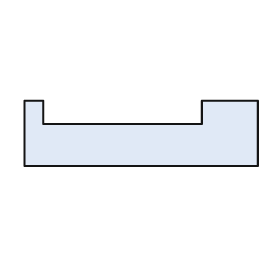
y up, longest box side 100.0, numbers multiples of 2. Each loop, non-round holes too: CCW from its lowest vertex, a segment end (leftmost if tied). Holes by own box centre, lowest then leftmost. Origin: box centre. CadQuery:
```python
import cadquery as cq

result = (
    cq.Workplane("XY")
    .moveTo(-50.0, -14.0)
    .lineTo(50.0, -14.0)
    .lineTo(50.0, 14.0)
    .lineTo(26.0, 14.0)
    .lineTo(26.0, 4.0)
    .lineTo(-42.0, 4.0)
    .lineTo(-42.0, 14.0)
    .lineTo(-50.0, 14.0)
    .close()
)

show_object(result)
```